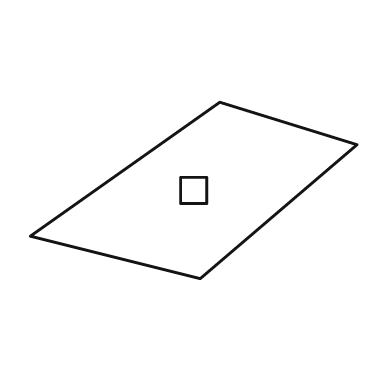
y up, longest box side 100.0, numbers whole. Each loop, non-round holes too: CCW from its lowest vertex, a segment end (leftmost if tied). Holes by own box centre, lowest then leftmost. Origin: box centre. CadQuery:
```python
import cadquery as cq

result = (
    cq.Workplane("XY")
    .moveTo(2.0, -27.0)
    .lineTo(50.0, 14.0)
    .lineTo(8.0, 27.0)
    .lineTo(-50.0, -14.0)
    .close()
    .moveTo(-4.0, -4.0)
    .lineTo(4.0, -4.0)
    .lineTo(4.0, 4.0)
    .lineTo(-4.0, 4.0)
    .close()
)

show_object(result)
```